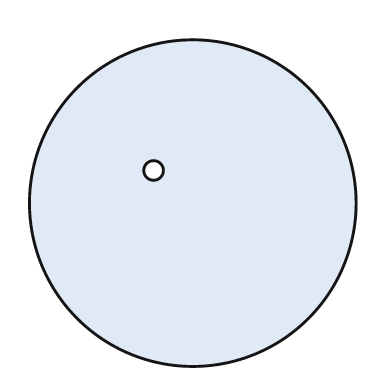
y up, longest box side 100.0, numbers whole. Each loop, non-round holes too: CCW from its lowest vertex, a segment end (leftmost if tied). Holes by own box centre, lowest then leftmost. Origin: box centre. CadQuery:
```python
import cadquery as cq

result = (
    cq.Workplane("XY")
    .moveTo(0.0, 0.0)
    .circle(50.0)
    .moveTo(-12.0, 10.0)
    .circle(3.0)
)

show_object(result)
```